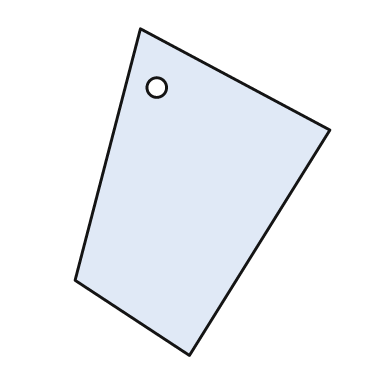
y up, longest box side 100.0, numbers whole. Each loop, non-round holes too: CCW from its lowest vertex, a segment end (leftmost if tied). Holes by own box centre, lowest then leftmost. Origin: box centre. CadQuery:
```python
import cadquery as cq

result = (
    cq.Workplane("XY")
    .moveTo(-4.0, -50.0)
    .lineTo(39.0, 19.0)
    .lineTo(-19.0, 50.0)
    .lineTo(-39.0, -27.0)
    .close()
    .moveTo(-14.0, 32.0)
    .circle(3.0)
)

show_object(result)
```